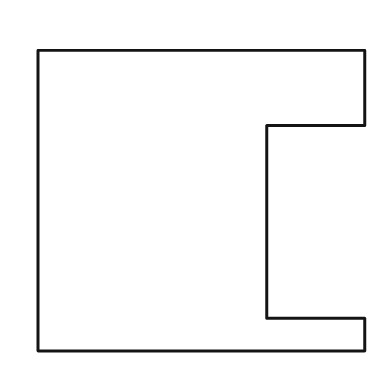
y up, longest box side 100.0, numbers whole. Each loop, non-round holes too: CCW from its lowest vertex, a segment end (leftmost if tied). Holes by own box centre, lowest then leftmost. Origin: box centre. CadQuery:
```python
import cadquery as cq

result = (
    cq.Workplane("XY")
    .moveTo(-50.0, -46.0)
    .lineTo(50.0, -46.0)
    .lineTo(50.0, -36.0)
    .lineTo(20.0, -36.0)
    .lineTo(20.0, 23.0)
    .lineTo(50.0, 23.0)
    .lineTo(50.0, 46.0)
    .lineTo(-50.0, 46.0)
    .close()
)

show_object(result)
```